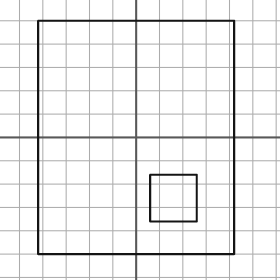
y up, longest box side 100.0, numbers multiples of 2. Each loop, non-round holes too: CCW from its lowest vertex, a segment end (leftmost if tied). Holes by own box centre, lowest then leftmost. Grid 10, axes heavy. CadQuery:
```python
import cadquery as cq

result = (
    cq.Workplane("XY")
    .moveTo(-42.0, -50.0)
    .lineTo(42.0, -50.0)
    .lineTo(42.0, 50.0)
    .lineTo(-42.0, 50.0)
    .close()
    .moveTo(6.0, -36.0)
    .lineTo(26.0, -36.0)
    .lineTo(26.0, -16.0)
    .lineTo(6.0, -16.0)
    .close()
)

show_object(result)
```